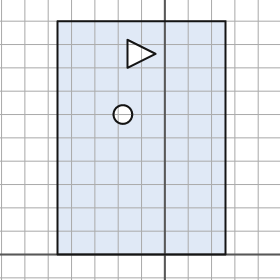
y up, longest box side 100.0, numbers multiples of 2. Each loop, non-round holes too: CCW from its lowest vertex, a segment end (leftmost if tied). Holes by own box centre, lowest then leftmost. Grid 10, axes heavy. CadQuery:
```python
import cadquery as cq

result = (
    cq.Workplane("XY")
    .moveTo(-46.0, 0.0)
    .lineTo(26.0, 0.0)
    .lineTo(26.0, 100.0)
    .lineTo(-46.0, 100.0)
    .close()
    .moveTo(-18.0, 60.0)
    .circle(4.0)
    .moveTo(-16.0, 80.0)
    .lineTo(-4.0, 86.0)
    .lineTo(-16.0, 92.0)
    .close()
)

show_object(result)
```